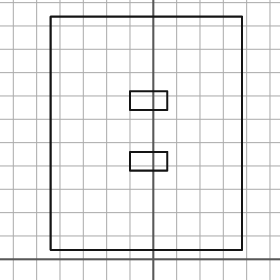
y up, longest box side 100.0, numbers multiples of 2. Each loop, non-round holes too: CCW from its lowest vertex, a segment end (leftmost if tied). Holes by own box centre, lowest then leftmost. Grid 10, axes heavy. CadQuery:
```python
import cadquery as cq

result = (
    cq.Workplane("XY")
    .moveTo(-44.0, 4.0)
    .lineTo(38.0, 4.0)
    .lineTo(38.0, 104.0)
    .lineTo(-44.0, 104.0)
    .close()
    .moveTo(-10.0, 38.0)
    .lineTo(6.0, 38.0)
    .lineTo(6.0, 46.0)
    .lineTo(-10.0, 46.0)
    .close()
    .moveTo(-10.0, 64.0)
    .lineTo(6.0, 64.0)
    .lineTo(6.0, 72.0)
    .lineTo(-10.0, 72.0)
    .close()
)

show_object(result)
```